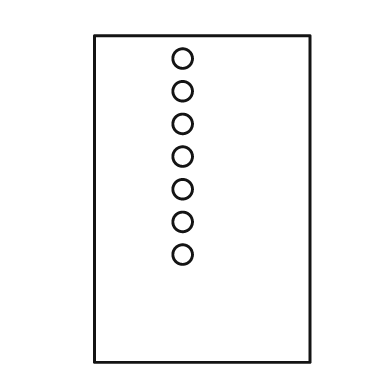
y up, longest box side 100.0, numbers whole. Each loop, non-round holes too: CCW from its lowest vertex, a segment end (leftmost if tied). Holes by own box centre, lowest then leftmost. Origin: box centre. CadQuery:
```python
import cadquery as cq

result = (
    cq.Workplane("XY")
    .moveTo(-33.0, -50.0)
    .lineTo(33.0, -50.0)
    .lineTo(33.0, 50.0)
    .lineTo(-33.0, 50.0)
    .close()
    .moveTo(-6.0, -17.0)
    .circle(3.0)
    .moveTo(-6.0, -7.0)
    .circle(3.0)
    .moveTo(-6.0, 3.0)
    .circle(3.0)
    .moveTo(-6.0, 13.0)
    .circle(3.0)
    .moveTo(-6.0, 23.0)
    .circle(3.0)
    .moveTo(-6.0, 33.0)
    .circle(3.0)
    .moveTo(-6.0, 43.0)
    .circle(3.0)
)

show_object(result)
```